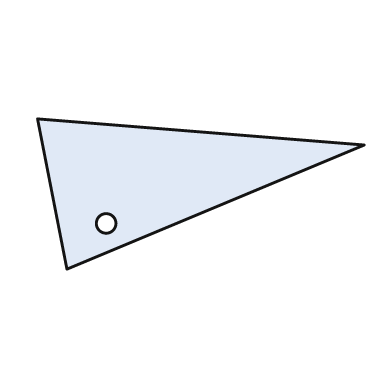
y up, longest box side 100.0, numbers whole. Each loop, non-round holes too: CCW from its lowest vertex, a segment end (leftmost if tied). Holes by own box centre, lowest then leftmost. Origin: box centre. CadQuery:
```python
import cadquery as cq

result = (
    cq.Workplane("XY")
    .moveTo(-41.0, -23.0)
    .lineTo(50.0, 15.0)
    .lineTo(-50.0, 23.0)
    .close()
    .moveTo(-29.0, -9.0)
    .circle(3.0)
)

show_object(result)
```